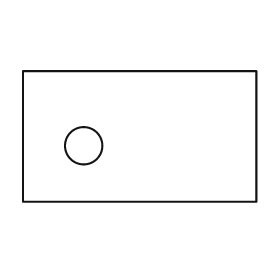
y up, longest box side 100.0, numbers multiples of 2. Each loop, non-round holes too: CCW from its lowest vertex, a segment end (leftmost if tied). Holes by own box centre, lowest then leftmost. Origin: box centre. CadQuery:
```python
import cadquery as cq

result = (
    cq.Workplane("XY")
    .moveTo(-50.0, -28.0)
    .lineTo(50.0, -28.0)
    .lineTo(50.0, 28.0)
    .lineTo(-50.0, 28.0)
    .close()
    .moveTo(-24.0, -4.0)
    .circle(8.0)
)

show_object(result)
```